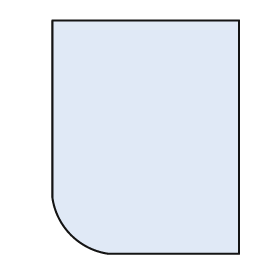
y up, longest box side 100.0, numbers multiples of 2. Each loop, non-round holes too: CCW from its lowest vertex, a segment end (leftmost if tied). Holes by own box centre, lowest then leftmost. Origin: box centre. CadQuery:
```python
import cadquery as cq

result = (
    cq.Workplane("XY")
    .moveTo(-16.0, -50.0)
    .lineTo(40.0, -50.0)
    .lineTo(40.0, 50.0)
    .lineTo(-40.0, 50.0)
    .lineTo(-40.0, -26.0)
    .threePointArc((-32.0, -42.0), (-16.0, -50.0))
    .close()
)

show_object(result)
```